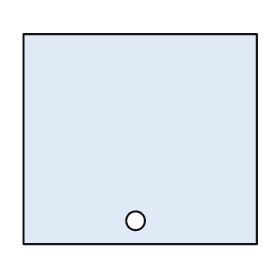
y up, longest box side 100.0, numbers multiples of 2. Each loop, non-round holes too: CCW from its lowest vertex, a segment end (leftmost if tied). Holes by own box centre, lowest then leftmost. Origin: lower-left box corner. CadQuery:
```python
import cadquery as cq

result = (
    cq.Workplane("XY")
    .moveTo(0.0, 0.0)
    .lineTo(100.0, 0.0)
    .lineTo(100.0, 90.0)
    .lineTo(0.0, 90.0)
    .close()
    .moveTo(48.0, 10.0)
    .circle(4.0)
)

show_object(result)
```